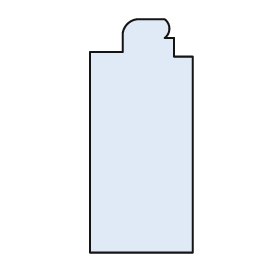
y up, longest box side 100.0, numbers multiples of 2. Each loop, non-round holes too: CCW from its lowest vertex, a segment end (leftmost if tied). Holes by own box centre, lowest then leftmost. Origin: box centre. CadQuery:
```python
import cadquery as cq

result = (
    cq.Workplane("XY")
    .moveTo(-22.0, -50.0)
    .lineTo(22.0, -50.0)
    .lineTo(22.0, 34.0)
    .lineTo(14.0, 34.0)
    .lineTo(14.0, 42.0)
    .lineTo(10.0, 42.0)
    .threePointArc((12.0, 46.0), (10.0, 50.0))
    .lineTo(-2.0, 50.0)
    .threePointArc((-6.0, 48.0), (-8.0, 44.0))
    .lineTo(-8.0, 36.0)
    .lineTo(-22.0, 36.0)
    .close()
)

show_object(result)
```